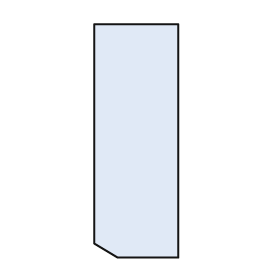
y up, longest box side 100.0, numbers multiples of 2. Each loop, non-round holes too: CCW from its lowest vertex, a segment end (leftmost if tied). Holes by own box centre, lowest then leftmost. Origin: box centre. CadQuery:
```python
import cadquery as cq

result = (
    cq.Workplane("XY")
    .moveTo(-8.0, -50.0)
    .lineTo(18.0, -50.0)
    .lineTo(18.0, 50.0)
    .lineTo(-18.0, 50.0)
    .lineTo(-18.0, -44.0)
    .close()
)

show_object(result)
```